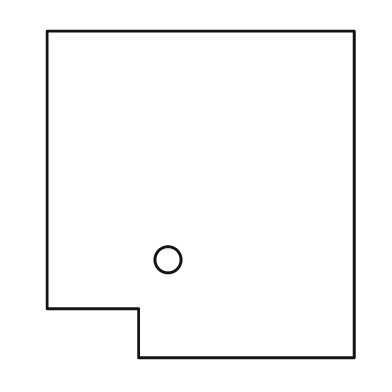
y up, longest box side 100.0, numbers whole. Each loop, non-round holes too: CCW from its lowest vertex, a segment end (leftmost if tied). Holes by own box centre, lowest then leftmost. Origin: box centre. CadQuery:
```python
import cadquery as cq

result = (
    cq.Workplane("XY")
    .moveTo(-19.0, -50.0)
    .lineTo(47.0, -50.0)
    .lineTo(47.0, 50.0)
    .lineTo(-47.0, 50.0)
    .lineTo(-47.0, -35.0)
    .lineTo(-19.0, -35.0)
    .close()
    .moveTo(-10.0, -20.0)
    .circle(4.0)
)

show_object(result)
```